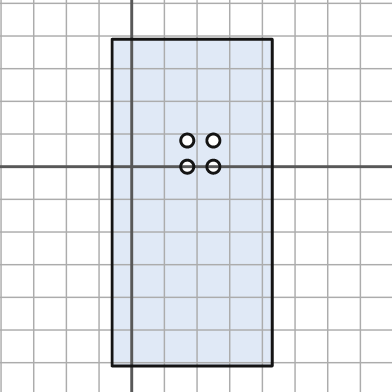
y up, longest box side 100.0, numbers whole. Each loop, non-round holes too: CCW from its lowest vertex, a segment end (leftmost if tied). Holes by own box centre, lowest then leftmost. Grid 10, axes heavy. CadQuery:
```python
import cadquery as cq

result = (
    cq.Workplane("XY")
    .moveTo(-6.0, -61.0)
    .lineTo(43.0, -61.0)
    .lineTo(43.0, 39.0)
    .lineTo(-6.0, 39.0)
    .close()
    .moveTo(17.0, 0.0)
    .circle(2.0)
    .moveTo(25.0, 0.0)
    .circle(2.0)
    .moveTo(17.0, 8.0)
    .circle(2.0)
    .moveTo(25.0, 8.0)
    .circle(2.0)
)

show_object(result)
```